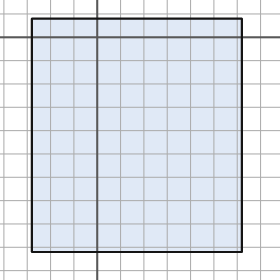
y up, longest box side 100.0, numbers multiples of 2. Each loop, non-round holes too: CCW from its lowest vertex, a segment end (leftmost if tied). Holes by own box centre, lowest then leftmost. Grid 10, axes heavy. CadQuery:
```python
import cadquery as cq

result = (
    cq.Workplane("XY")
    .moveTo(-28.0, -92.0)
    .lineTo(62.0, -92.0)
    .lineTo(62.0, 8.0)
    .lineTo(-28.0, 8.0)
    .close()
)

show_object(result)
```